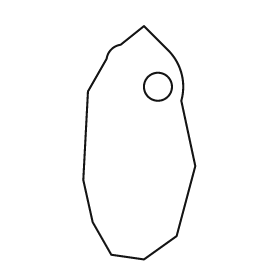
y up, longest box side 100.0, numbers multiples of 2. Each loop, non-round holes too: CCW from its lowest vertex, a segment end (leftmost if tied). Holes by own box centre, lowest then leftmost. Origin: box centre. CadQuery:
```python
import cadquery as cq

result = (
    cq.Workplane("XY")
    .moveTo(2.0, -50.0)
    .lineTo(16.0, -40.0)
    .lineTo(24.0, -10.0)
    .lineTo(18.0, 18.0)
    .threePointArc((18.0, 30.0), (12.0, 40.0))
    .lineTo(2.0, 50.0)
    .lineTo(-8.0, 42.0)
    .threePointArc((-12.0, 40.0), (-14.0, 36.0))
    .lineTo(-22.0, 22.0)
    .lineTo(-24.0, -16.0)
    .lineTo(-20.0, -34.0)
    .lineTo(-12.0, -48.0)
    .close()
    .moveTo(8.0, 24.0)
    .circle(6.0)
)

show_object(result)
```